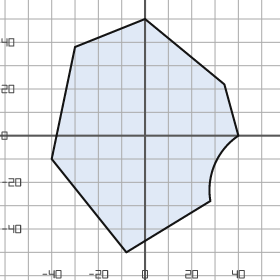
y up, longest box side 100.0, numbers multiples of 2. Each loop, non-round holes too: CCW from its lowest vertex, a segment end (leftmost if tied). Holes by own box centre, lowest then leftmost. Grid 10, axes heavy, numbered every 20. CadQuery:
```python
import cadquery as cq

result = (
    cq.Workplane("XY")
    .moveTo(-8.0, -50.0)
    .lineTo(28.0, -28.0)
    .threePointArc((30.0, -12.0), (40.0, 0.0))
    .lineTo(34.0, 22.0)
    .lineTo(0.0, 50.0)
    .lineTo(-30.0, 38.0)
    .lineTo(-40.0, -10.0)
    .close()
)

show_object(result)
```